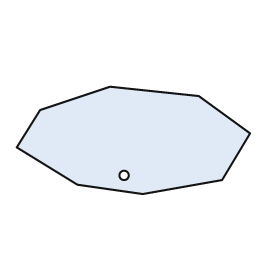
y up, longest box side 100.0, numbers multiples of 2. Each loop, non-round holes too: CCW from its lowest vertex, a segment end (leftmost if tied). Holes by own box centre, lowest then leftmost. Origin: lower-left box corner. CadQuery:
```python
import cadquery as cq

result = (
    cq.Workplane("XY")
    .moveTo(54.0, 0.0)
    .lineTo(88.0, 6.0)
    .lineTo(100.0, 26.0)
    .lineTo(78.0, 42.0)
    .lineTo(40.0, 46.0)
    .lineTo(10.0, 36.0)
    .lineTo(0.0, 20.0)
    .lineTo(26.0, 4.0)
    .close()
    .moveTo(46.0, 8.0)
    .circle(2.0)
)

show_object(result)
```